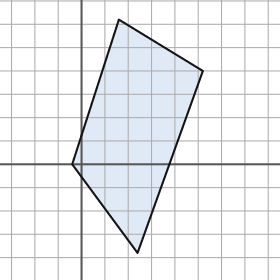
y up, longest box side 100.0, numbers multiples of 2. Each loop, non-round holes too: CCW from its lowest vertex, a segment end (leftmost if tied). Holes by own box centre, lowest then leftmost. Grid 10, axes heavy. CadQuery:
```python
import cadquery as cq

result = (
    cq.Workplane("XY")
    .moveTo(24.0, -38.0)
    .lineTo(52.0, 40.0)
    .lineTo(16.0, 62.0)
    .lineTo(-4.0, 0.0)
    .close()
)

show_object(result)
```